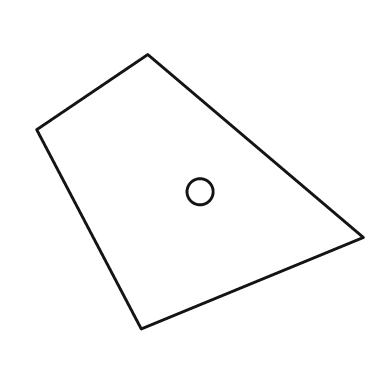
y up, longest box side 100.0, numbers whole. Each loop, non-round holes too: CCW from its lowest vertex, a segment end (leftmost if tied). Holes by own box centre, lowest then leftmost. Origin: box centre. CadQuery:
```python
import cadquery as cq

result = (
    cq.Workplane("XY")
    .moveTo(-18.0, -42.0)
    .lineTo(50.0, -14.0)
    .lineTo(-16.0, 42.0)
    .lineTo(-50.0, 19.0)
    .close()
    .moveTo(0.0, 0.0)
    .circle(4.0)
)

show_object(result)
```